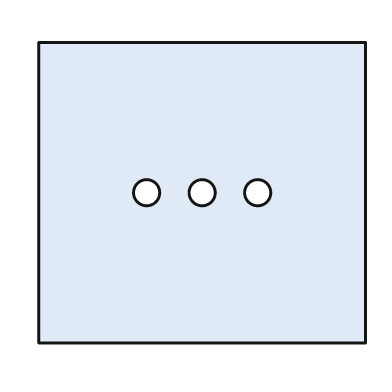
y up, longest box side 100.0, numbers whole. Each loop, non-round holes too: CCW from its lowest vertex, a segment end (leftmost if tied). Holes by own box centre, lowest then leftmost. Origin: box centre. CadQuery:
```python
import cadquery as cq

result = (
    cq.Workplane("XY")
    .moveTo(-50.0, -46.0)
    .lineTo(50.0, -46.0)
    .lineTo(50.0, 46.0)
    .lineTo(-50.0, 46.0)
    .close()
    .moveTo(-17.0, 0.0)
    .circle(4.0)
    .moveTo(0.0, 0.0)
    .circle(4.0)
    .moveTo(17.0, 0.0)
    .circle(4.0)
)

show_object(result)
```